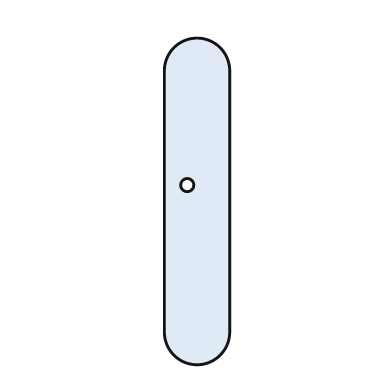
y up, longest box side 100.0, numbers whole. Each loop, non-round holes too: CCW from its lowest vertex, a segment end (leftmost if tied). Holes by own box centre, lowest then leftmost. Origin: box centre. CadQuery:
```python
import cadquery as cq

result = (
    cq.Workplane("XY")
    .moveTo(-10.0, -40.0)
    .threePointArc((0.0, -50.0), (10.0, -40.0))
    .lineTo(10.0, 40.0)
    .threePointArc((0.0, 50.0), (-10.0, 40.0))
    .close()
    .moveTo(-3.0, 5.0)
    .circle(2.0)
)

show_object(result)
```